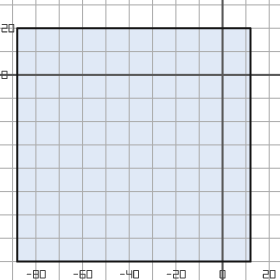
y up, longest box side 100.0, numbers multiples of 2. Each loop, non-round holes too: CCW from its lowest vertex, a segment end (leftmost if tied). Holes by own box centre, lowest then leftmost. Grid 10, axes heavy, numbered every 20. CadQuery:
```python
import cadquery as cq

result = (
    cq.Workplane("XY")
    .moveTo(-88.0, -80.0)
    .lineTo(12.0, -80.0)
    .lineTo(12.0, 20.0)
    .lineTo(-88.0, 20.0)
    .close()
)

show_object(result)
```